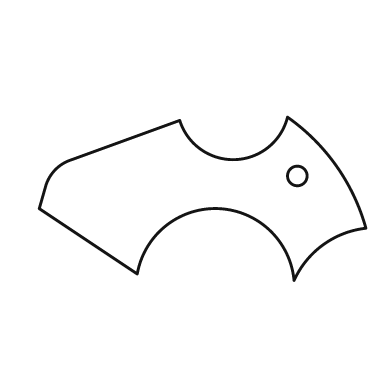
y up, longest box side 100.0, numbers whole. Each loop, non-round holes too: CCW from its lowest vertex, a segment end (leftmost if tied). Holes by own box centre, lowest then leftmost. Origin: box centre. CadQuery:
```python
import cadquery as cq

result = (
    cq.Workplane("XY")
    .moveTo(28.0, -25.0)
    .threePointArc((37.0, -14.0), (50.0, -9.0))
    .threePointArc((41.0, 10.0), (26.0, 25.0))
    .threePointArc((10.0, 12.0), (-7.0, 24.0))
    .lineTo(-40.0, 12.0)
    .threePointArc((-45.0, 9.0), (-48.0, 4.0))
    .lineTo(-50.0, -3.0)
    .lineTo(-20.0, -23.0)
    .threePointArc((5.0, -3.0), (28.0, -25.0))
    .close()
    .moveTo(29.0, 7.0)
    .circle(3.0)
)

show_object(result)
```